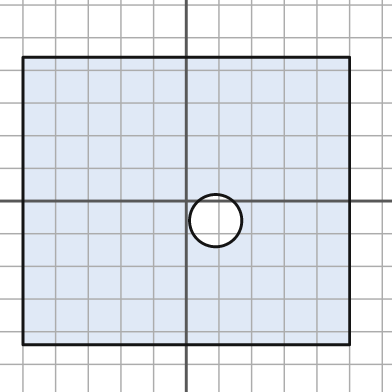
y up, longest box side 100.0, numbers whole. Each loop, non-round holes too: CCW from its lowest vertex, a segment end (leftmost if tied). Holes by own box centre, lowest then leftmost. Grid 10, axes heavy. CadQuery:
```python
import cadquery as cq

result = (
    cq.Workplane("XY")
    .moveTo(-50.0, -44.0)
    .lineTo(50.0, -44.0)
    .lineTo(50.0, 44.0)
    .lineTo(-50.0, 44.0)
    .close()
    .moveTo(9.0, -6.0)
    .circle(8.0)
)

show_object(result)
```